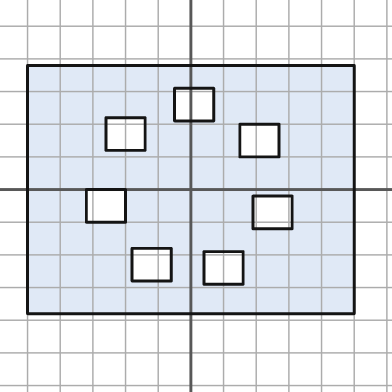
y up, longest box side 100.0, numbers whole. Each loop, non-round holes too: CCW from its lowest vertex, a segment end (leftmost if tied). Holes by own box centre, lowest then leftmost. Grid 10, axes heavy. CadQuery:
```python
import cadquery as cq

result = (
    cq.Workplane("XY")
    .moveTo(-50.0, -38.0)
    .lineTo(50.0, -38.0)
    .lineTo(50.0, 38.0)
    .lineTo(-50.0, 38.0)
    .close()
    .moveTo(4.0, -29.0)
    .lineTo(16.0, -29.0)
    .lineTo(16.0, -19.0)
    .lineTo(4.0, -19.0)
    .close()
    .moveTo(-18.0, -28.0)
    .lineTo(-6.0, -28.0)
    .lineTo(-6.0, -18.0)
    .lineTo(-18.0, -18.0)
    .close()
    .moveTo(19.0, -12.0)
    .lineTo(31.0, -12.0)
    .lineTo(31.0, -2.0)
    .lineTo(19.0, -2.0)
    .close()
    .moveTo(-32.0, -10.0)
    .lineTo(-20.0, -10.0)
    .lineTo(-20.0, 0.0)
    .lineTo(-32.0, 0.0)
    .close()
    .moveTo(15.0, 10.0)
    .lineTo(27.0, 10.0)
    .lineTo(27.0, 20.0)
    .lineTo(15.0, 20.0)
    .close()
    .moveTo(-26.0, 12.0)
    .lineTo(-14.0, 12.0)
    .lineTo(-14.0, 22.0)
    .lineTo(-26.0, 22.0)
    .close()
    .moveTo(-5.0, 21.0)
    .lineTo(7.0, 21.0)
    .lineTo(7.0, 31.0)
    .lineTo(-5.0, 31.0)
    .close()
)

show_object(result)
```